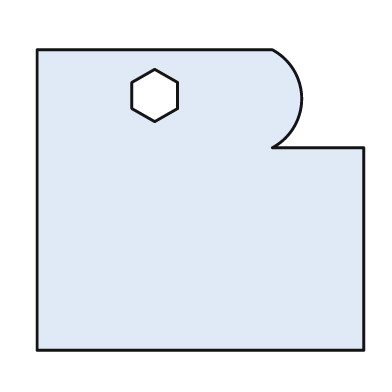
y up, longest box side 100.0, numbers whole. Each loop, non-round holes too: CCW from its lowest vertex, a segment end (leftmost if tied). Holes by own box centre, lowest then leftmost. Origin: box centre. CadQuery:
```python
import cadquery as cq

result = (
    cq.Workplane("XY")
    .moveTo(-50.0, -46.0)
    .lineTo(50.0, -46.0)
    .lineTo(50.0, 16.0)
    .lineTo(22.0, 16.0)
    .threePointArc((31.0, 31.0), (22.0, 46.0))
    .lineTo(-50.0, 46.0)
    .close()
    .moveTo(-14.0, 24.0)
    .lineTo(-7.0, 28.0)
    .lineTo(-7.0, 36.0)
    .lineTo(-14.0, 40.0)
    .lineTo(-21.0, 36.0)
    .lineTo(-21.0, 28.0)
    .close()
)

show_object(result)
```